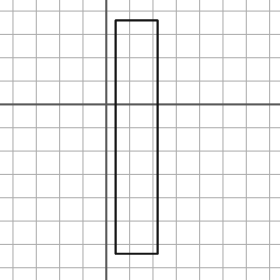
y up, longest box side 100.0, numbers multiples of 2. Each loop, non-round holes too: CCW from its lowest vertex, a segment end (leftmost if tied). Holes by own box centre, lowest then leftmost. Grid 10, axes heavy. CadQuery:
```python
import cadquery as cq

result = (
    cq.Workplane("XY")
    .moveTo(4.0, -64.0)
    .lineTo(22.0, -64.0)
    .lineTo(22.0, 36.0)
    .lineTo(4.0, 36.0)
    .close()
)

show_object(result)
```